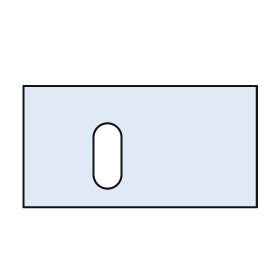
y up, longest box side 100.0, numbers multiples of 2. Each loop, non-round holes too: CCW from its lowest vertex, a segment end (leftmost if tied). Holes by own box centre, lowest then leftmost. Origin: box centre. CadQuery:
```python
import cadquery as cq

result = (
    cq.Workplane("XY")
    .moveTo(-50.0, -26.0)
    .lineTo(50.0, -26.0)
    .lineTo(50.0, 26.0)
    .lineTo(-50.0, 26.0)
    .close()
    .moveTo(-20.0, -12.0)
    .threePointArc((-14.0, -18.0), (-8.0, -12.0))
    .lineTo(-8.0, 4.0)
    .threePointArc((-14.0, 10.0), (-20.0, 4.0))
    .close()
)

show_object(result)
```